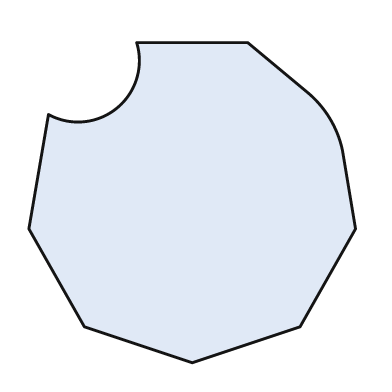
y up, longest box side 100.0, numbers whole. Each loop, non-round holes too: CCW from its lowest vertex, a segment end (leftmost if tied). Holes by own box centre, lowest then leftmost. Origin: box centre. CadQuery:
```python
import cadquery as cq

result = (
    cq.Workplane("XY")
    .moveTo(0.0, -49.0)
    .lineTo(33.0, -38.0)
    .lineTo(50.0, -8.0)
    .lineTo(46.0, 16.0)
    .threePointArc((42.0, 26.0), (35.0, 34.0))
    .lineTo(17.0, 49.0)
    .lineTo(-17.0, 49.0)
    .threePointArc((-23.0, 29.0), (-44.0, 27.0))
    .lineTo(-50.0, -8.0)
    .lineTo(-33.0, -38.0)
    .close()
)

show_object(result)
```